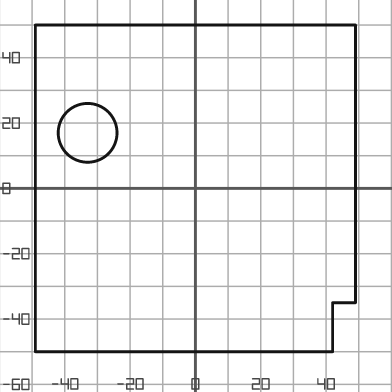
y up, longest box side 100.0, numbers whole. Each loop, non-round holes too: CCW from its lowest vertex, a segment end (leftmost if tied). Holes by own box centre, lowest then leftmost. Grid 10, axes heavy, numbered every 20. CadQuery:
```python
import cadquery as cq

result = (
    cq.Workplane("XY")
    .moveTo(-49.0, -50.0)
    .lineTo(42.0, -50.0)
    .lineTo(42.0, -35.0)
    .lineTo(49.0, -35.0)
    .lineTo(49.0, 50.0)
    .lineTo(-49.0, 50.0)
    .close()
    .moveTo(-33.0, 17.0)
    .circle(9.0)
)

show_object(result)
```